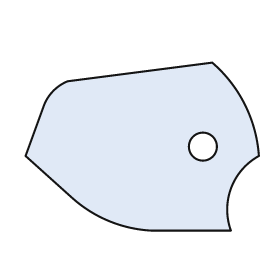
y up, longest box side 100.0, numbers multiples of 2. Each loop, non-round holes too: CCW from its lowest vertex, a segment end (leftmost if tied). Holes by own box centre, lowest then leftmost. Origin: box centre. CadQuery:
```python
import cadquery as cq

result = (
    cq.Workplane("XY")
    .moveTo(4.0, -36.0)
    .lineTo(38.0, -36.0)
    .threePointArc((38.0, -18.0), (50.0, -4.0))
    .threePointArc((44.0, 18.0), (30.0, 36.0))
    .lineTo(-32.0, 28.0)
    .threePointArc((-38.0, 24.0), (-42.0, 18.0))
    .lineTo(-50.0, -4.0)
    .lineTo(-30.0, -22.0)
    .threePointArc((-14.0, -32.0), (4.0, -36.0))
    .close()
    .moveTo(26.0, 0.0)
    .circle(6.0)
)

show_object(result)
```